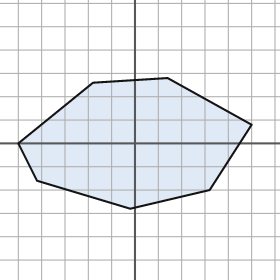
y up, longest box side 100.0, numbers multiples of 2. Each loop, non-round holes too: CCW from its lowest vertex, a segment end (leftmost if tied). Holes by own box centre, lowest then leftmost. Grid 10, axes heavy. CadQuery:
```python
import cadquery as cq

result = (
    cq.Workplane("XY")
    .moveTo(-2.0, -28.0)
    .lineTo(32.0, -20.0)
    .lineTo(50.0, 8.0)
    .lineTo(14.0, 28.0)
    .lineTo(-18.0, 26.0)
    .lineTo(-50.0, 0.0)
    .lineTo(-42.0, -16.0)
    .close()
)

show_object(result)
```